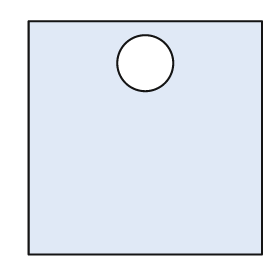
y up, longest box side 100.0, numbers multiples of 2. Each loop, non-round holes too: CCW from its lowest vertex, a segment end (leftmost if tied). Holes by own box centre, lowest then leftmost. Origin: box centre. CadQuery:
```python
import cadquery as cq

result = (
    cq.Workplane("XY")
    .moveTo(-50.0, -50.0)
    .lineTo(50.0, -50.0)
    .lineTo(50.0, 50.0)
    .lineTo(-50.0, 50.0)
    .close()
    .moveTo(0.0, 32.0)
    .circle(12.0)
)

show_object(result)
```